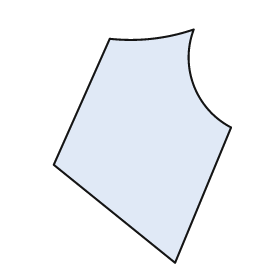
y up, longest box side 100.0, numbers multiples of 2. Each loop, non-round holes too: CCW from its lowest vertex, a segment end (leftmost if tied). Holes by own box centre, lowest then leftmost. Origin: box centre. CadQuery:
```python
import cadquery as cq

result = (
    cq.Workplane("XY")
    .moveTo(14.0, -50.0)
    .lineTo(38.0, 8.0)
    .threePointArc((22.0, 26.0), (22.0, 50.0))
    .threePointArc((4.0, 46.0), (-14.0, 46.0))
    .lineTo(-38.0, -8.0)
    .close()
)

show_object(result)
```